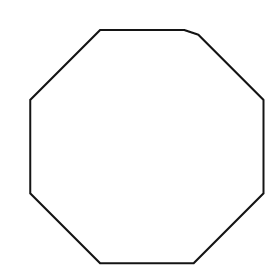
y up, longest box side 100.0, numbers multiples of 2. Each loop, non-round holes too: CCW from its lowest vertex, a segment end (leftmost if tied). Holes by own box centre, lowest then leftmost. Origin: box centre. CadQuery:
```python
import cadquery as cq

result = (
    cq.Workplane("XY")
    .moveTo(-20.0, -50.0)
    .lineTo(20.0, -50.0)
    .lineTo(50.0, -20.0)
    .lineTo(50.0, 20.0)
    .lineTo(22.0, 48.0)
    .lineTo(16.0, 50.0)
    .lineTo(-20.0, 50.0)
    .lineTo(-50.0, 20.0)
    .lineTo(-50.0, -20.0)
    .close()
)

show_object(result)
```